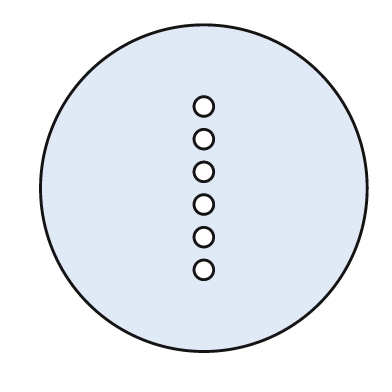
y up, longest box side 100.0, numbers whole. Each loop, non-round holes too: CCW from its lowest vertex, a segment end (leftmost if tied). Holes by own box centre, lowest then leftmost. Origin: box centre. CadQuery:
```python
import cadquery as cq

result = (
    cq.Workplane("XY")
    .moveTo(0.0, 0.0)
    .circle(50.0)
    .moveTo(0.0, -25.0)
    .circle(3.0)
    .moveTo(0.0, -15.0)
    .circle(3.0)
    .moveTo(0.0, -5.0)
    .circle(3.0)
    .moveTo(0.0, 5.0)
    .circle(3.0)
    .moveTo(0.0, 15.0)
    .circle(3.0)
    .moveTo(0.0, 25.0)
    .circle(3.0)
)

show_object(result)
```